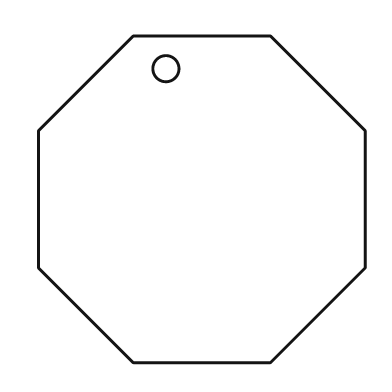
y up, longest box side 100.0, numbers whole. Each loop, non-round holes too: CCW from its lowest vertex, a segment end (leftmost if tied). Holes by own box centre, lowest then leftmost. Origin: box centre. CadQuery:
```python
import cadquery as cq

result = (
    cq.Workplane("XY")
    .moveTo(-21.0, -50.0)
    .lineTo(21.0, -50.0)
    .lineTo(50.0, -21.0)
    .lineTo(50.0, 21.0)
    .lineTo(21.0, 50.0)
    .lineTo(-21.0, 50.0)
    .lineTo(-50.0, 21.0)
    .lineTo(-50.0, -21.0)
    .close()
    .moveTo(-11.0, 40.0)
    .circle(4.0)
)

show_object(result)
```